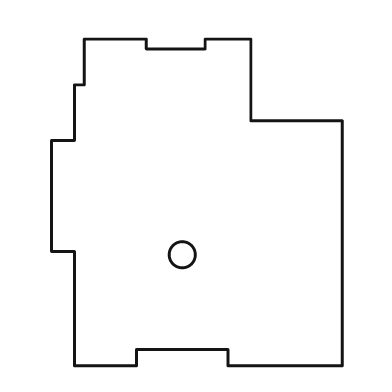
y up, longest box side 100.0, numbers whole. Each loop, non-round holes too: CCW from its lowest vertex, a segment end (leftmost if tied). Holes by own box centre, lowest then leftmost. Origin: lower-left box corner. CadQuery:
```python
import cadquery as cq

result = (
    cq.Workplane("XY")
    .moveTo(7.0, 0.0)
    .lineTo(26.0, 0.0)
    .lineTo(26.0, 5.0)
    .lineTo(54.0, 5.0)
    .lineTo(54.0, 0.0)
    .lineTo(89.0, 0.0)
    .lineTo(89.0, 75.0)
    .lineTo(61.0, 75.0)
    .lineTo(61.0, 100.0)
    .lineTo(47.0, 100.0)
    .lineTo(47.0, 97.0)
    .lineTo(29.0, 97.0)
    .lineTo(29.0, 100.0)
    .lineTo(10.0, 100.0)
    .lineTo(10.0, 86.0)
    .lineTo(7.0, 86.0)
    .lineTo(7.0, 69.0)
    .lineTo(0.0, 69.0)
    .lineTo(0.0, 35.0)
    .lineTo(7.0, 35.0)
    .close()
    .moveTo(40.0, 34.0)
    .circle(4.0)
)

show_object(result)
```